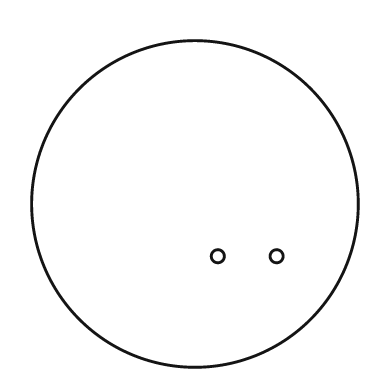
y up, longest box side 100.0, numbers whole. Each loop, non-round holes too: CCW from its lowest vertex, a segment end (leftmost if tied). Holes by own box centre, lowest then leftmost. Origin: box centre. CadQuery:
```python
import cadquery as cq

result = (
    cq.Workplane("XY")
    .moveTo(0.0, 0.0)
    .circle(50.0)
    .moveTo(7.0, -16.0)
    .circle(2.0)
    .moveTo(25.0, -16.0)
    .circle(2.0)
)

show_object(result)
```